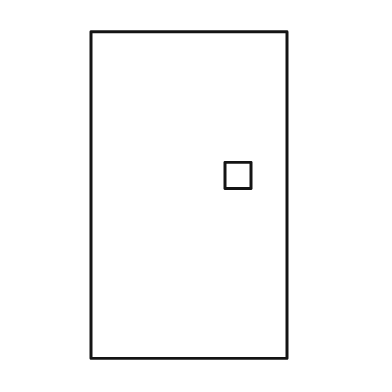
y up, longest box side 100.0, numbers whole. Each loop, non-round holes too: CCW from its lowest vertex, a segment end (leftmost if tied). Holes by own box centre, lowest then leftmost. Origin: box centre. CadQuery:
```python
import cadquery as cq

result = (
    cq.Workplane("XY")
    .moveTo(-30.0, -50.0)
    .lineTo(30.0, -50.0)
    .lineTo(30.0, 50.0)
    .lineTo(-30.0, 50.0)
    .close()
    .moveTo(11.0, 2.0)
    .lineTo(19.0, 2.0)
    .lineTo(19.0, 10.0)
    .lineTo(11.0, 10.0)
    .close()
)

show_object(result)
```